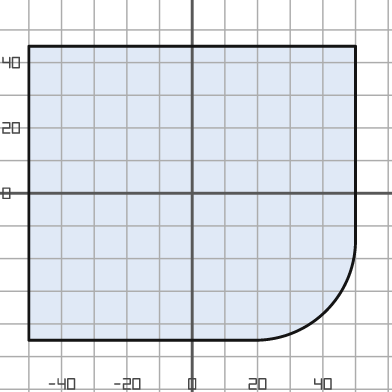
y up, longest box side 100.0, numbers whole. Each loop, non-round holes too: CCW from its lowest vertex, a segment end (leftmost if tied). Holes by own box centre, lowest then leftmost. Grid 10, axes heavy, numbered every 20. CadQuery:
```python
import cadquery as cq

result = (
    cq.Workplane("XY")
    .moveTo(-50.0, -45.0)
    .lineTo(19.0, -45.0)
    .threePointArc((41.0, -36.0), (50.0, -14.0))
    .lineTo(50.0, 45.0)
    .lineTo(-50.0, 45.0)
    .close()
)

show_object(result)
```